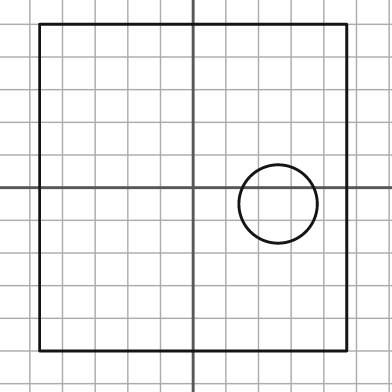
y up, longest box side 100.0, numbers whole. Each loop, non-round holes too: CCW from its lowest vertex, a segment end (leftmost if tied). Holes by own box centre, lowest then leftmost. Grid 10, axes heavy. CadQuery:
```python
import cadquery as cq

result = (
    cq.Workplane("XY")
    .moveTo(-47.0, -50.0)
    .lineTo(47.0, -50.0)
    .lineTo(47.0, 50.0)
    .lineTo(-47.0, 50.0)
    .close()
    .moveTo(26.0, -5.0)
    .circle(12.0)
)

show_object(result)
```